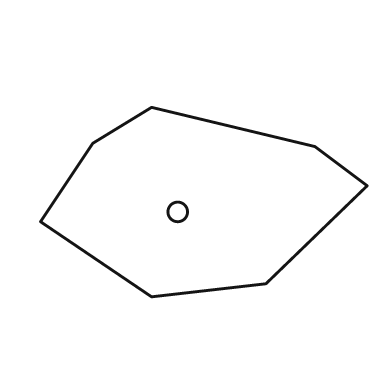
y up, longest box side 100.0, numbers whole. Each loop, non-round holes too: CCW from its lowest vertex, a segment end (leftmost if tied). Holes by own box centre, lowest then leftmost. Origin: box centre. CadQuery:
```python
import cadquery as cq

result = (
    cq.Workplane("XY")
    .moveTo(-16.0, -29.0)
    .lineTo(19.0, -25.0)
    .lineTo(50.0, 5.0)
    .lineTo(34.0, 17.0)
    .lineTo(-16.0, 29.0)
    .lineTo(-34.0, 18.0)
    .lineTo(-50.0, -6.0)
    .close()
    .moveTo(-8.0, -3.0)
    .circle(3.0)
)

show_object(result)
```